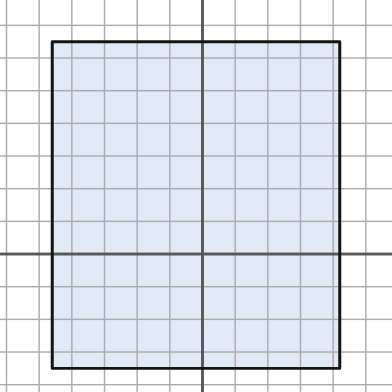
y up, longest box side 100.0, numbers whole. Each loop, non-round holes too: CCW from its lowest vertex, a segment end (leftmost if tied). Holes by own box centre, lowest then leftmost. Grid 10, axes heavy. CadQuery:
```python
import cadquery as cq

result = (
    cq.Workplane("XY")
    .moveTo(-46.0, -35.0)
    .lineTo(42.0, -35.0)
    .lineTo(42.0, 65.0)
    .lineTo(-46.0, 65.0)
    .close()
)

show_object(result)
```